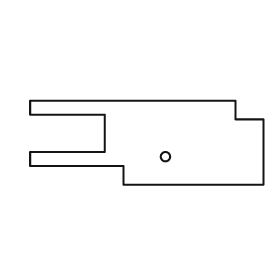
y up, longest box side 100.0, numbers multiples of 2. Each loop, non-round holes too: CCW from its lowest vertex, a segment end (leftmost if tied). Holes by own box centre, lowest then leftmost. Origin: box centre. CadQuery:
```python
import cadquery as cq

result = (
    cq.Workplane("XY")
    .moveTo(-10.0, -18.0)
    .lineTo(50.0, -18.0)
    .lineTo(50.0, 10.0)
    .lineTo(38.0, 10.0)
    .lineTo(38.0, 18.0)
    .lineTo(-50.0, 18.0)
    .lineTo(-50.0, 12.0)
    .lineTo(-18.0, 12.0)
    .lineTo(-18.0, -4.0)
    .lineTo(-50.0, -4.0)
    .lineTo(-50.0, -10.0)
    .lineTo(-10.0, -10.0)
    .close()
    .moveTo(8.0, -6.0)
    .circle(2.0)
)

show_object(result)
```